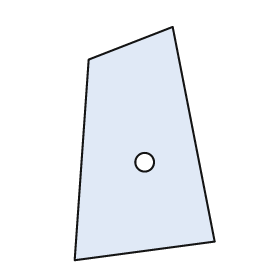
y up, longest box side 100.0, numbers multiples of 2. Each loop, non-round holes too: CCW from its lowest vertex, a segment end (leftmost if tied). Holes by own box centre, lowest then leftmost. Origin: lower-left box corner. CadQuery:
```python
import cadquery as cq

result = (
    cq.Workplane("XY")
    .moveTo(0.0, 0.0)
    .lineTo(60.0, 8.0)
    .lineTo(42.0, 100.0)
    .lineTo(6.0, 86.0)
    .close()
    .moveTo(30.0, 42.0)
    .circle(4.0)
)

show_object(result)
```